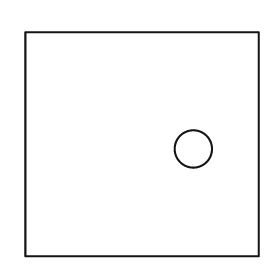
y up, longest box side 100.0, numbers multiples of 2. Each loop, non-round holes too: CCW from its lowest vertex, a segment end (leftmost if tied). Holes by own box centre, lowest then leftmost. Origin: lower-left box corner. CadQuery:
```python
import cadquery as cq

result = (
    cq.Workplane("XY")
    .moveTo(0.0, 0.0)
    .lineTo(100.0, 0.0)
    .lineTo(100.0, 96.0)
    .lineTo(0.0, 96.0)
    .close()
    .moveTo(72.0, 46.0)
    .circle(8.0)
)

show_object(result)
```